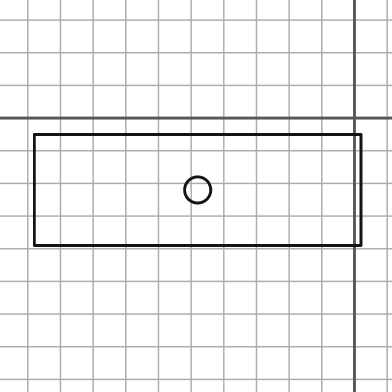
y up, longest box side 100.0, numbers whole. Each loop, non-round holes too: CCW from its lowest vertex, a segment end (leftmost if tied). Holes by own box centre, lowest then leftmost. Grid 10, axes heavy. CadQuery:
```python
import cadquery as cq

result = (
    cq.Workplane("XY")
    .moveTo(-98.0, -39.0)
    .lineTo(2.0, -39.0)
    .lineTo(2.0, -5.0)
    .lineTo(-98.0, -5.0)
    .close()
    .moveTo(-48.0, -22.0)
    .circle(4.0)
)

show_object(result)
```